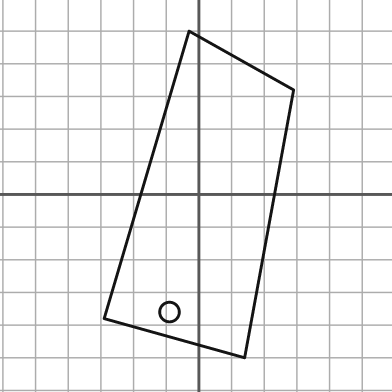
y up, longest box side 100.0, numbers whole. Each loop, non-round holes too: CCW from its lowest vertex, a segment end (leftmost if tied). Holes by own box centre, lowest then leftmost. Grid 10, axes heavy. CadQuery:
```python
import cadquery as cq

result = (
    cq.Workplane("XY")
    .moveTo(14.0, -50.0)
    .lineTo(29.0, 32.0)
    .lineTo(-3.0, 50.0)
    .lineTo(-29.0, -38.0)
    .close()
    .moveTo(-9.0, -36.0)
    .circle(3.0)
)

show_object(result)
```